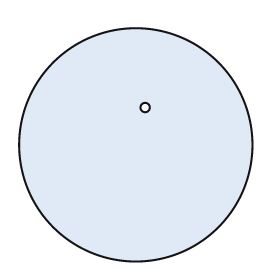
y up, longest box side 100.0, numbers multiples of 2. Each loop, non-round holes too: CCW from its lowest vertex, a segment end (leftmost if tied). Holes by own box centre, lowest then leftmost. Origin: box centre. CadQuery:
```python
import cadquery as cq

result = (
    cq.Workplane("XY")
    .moveTo(0.0, 0.0)
    .circle(50.0)
    .moveTo(4.0, 16.0)
    .circle(2.0)
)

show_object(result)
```